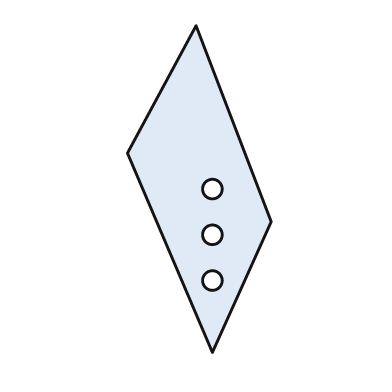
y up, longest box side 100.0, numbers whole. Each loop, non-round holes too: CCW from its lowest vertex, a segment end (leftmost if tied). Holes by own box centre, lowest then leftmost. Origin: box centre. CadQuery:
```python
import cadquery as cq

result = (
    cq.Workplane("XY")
    .moveTo(4.0, -50.0)
    .lineTo(22.0, -10.0)
    .lineTo(-1.0, 50.0)
    .lineTo(-22.0, 11.0)
    .close()
    .moveTo(4.0, -28.0)
    .circle(3.0)
    .moveTo(4.0, -14.0)
    .circle(3.0)
    .moveTo(4.0, 0.0)
    .circle(3.0)
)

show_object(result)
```